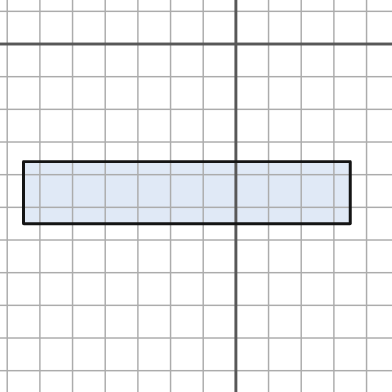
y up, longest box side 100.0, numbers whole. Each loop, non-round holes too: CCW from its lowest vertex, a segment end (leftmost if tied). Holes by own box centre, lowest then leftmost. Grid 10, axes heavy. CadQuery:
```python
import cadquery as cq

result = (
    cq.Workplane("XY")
    .moveTo(-65.0, -55.0)
    .lineTo(35.0, -55.0)
    .lineTo(35.0, -36.0)
    .lineTo(-65.0, -36.0)
    .close()
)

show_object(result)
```